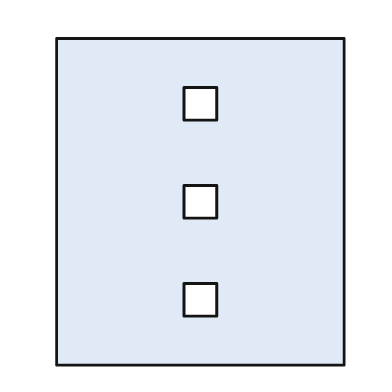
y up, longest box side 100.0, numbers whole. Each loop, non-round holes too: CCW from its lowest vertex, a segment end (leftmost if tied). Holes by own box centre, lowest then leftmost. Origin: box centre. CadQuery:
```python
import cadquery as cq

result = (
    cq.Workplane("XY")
    .moveTo(-44.0, -50.0)
    .lineTo(44.0, -50.0)
    .lineTo(44.0, 50.0)
    .lineTo(-44.0, 50.0)
    .close()
    .moveTo(-5.0, -35.0)
    .lineTo(5.0, -35.0)
    .lineTo(5.0, -25.0)
    .lineTo(-5.0, -25.0)
    .close()
    .moveTo(-5.0, -5.0)
    .lineTo(5.0, -5.0)
    .lineTo(5.0, 5.0)
    .lineTo(-5.0, 5.0)
    .close()
    .moveTo(-5.0, 25.0)
    .lineTo(5.0, 25.0)
    .lineTo(5.0, 35.0)
    .lineTo(-5.0, 35.0)
    .close()
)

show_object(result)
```